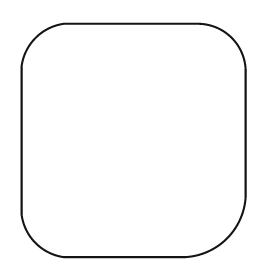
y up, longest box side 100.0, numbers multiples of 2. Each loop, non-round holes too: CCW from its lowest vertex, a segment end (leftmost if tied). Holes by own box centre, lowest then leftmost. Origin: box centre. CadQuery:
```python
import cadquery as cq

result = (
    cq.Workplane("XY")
    .moveTo(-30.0, -50.0)
    .lineTo(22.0, -50.0)
    .threePointArc((40.0, -42.0), (48.0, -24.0))
    .lineTo(48.0, 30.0)
    .threePointArc((42.0, 44.0), (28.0, 50.0))
    .lineTo(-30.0, 50.0)
    .threePointArc((-42.0, 44.0), (-48.0, 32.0))
    .lineTo(-48.0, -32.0)
    .threePointArc((-42.0, -44.0), (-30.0, -50.0))
    .close()
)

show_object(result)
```